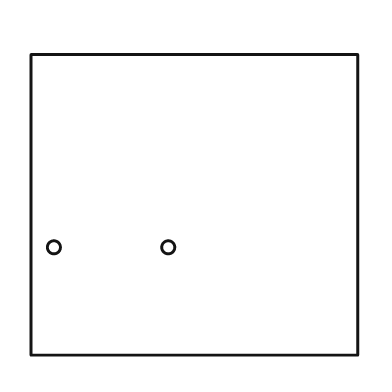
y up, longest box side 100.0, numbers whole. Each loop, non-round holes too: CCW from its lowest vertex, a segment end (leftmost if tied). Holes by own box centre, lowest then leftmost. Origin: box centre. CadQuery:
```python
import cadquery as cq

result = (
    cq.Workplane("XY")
    .moveTo(-50.0, -46.0)
    .lineTo(50.0, -46.0)
    .lineTo(50.0, 46.0)
    .lineTo(-50.0, 46.0)
    .close()
    .moveTo(-43.0, -13.0)
    .circle(2.0)
    .moveTo(-8.0, -13.0)
    .circle(2.0)
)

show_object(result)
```